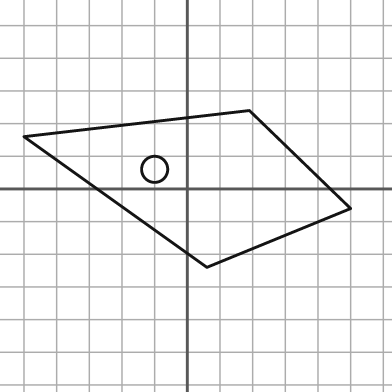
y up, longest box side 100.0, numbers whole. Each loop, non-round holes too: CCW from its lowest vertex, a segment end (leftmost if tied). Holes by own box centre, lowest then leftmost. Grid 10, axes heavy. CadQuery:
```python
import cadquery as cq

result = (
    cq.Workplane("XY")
    .moveTo(6.0, -24.0)
    .lineTo(50.0, -6.0)
    .lineTo(19.0, 24.0)
    .lineTo(-50.0, 16.0)
    .close()
    .moveTo(-10.0, 6.0)
    .circle(4.0)
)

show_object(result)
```